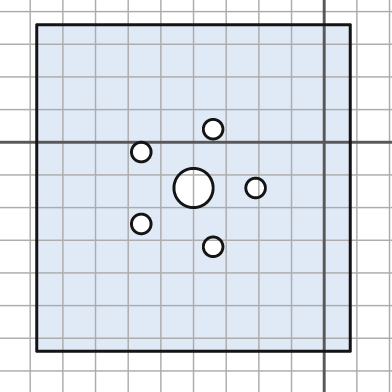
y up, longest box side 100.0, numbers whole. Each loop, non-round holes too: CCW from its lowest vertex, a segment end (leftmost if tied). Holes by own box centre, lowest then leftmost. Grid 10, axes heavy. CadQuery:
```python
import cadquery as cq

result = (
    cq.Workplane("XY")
    .moveTo(-88.0, -64.0)
    .lineTo(8.0, -64.0)
    .lineTo(8.0, 36.0)
    .lineTo(-88.0, 36.0)
    .close()
    .moveTo(-34.0, -32.0)
    .circle(3.0)
    .moveTo(-56.0, -25.0)
    .circle(3.0)
    .moveTo(-40.0, -14.0)
    .circle(6.0)
    .moveTo(-21.0, -14.0)
    .circle(3.0)
    .moveTo(-56.0, -3.0)
    .circle(3.0)
    .moveTo(-34.0, 4.0)
    .circle(3.0)
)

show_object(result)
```